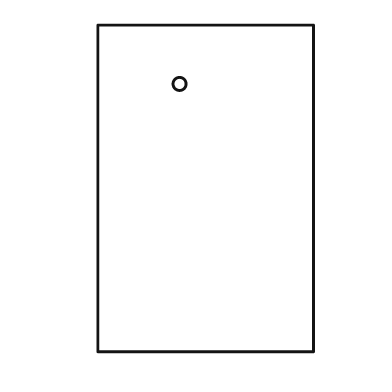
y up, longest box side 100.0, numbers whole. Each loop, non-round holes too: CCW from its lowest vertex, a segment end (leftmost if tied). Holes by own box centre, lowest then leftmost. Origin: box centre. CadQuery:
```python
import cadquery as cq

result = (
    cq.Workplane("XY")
    .moveTo(-33.0, -50.0)
    .lineTo(33.0, -50.0)
    .lineTo(33.0, 50.0)
    .lineTo(-33.0, 50.0)
    .close()
    .moveTo(-8.0, 32.0)
    .circle(2.0)
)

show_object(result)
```